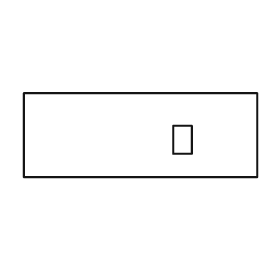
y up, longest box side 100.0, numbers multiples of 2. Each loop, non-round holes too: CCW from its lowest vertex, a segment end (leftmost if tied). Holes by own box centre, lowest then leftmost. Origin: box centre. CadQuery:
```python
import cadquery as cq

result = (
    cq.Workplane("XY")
    .moveTo(-50.0, -18.0)
    .lineTo(50.0, -18.0)
    .lineTo(50.0, 18.0)
    .lineTo(-50.0, 18.0)
    .close()
    .moveTo(14.0, -8.0)
    .lineTo(22.0, -8.0)
    .lineTo(22.0, 4.0)
    .lineTo(14.0, 4.0)
    .close()
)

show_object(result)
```